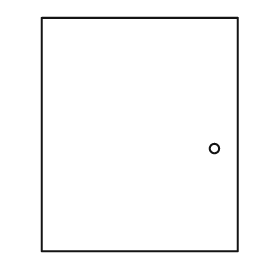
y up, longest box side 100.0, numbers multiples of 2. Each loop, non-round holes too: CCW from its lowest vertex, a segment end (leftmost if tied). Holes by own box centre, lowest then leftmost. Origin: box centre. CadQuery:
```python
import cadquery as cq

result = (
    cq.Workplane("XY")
    .moveTo(-42.0, -50.0)
    .lineTo(42.0, -50.0)
    .lineTo(42.0, 50.0)
    .lineTo(-42.0, 50.0)
    .close()
    .moveTo(32.0, -6.0)
    .circle(2.0)
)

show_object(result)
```